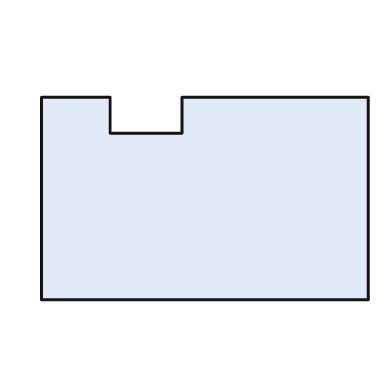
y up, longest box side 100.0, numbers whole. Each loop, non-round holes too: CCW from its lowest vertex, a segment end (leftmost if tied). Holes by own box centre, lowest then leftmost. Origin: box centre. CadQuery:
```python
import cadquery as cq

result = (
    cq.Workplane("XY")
    .moveTo(-50.0, -31.0)
    .lineTo(50.0, -31.0)
    .lineTo(50.0, 31.0)
    .lineTo(-7.0, 31.0)
    .lineTo(-7.0, 20.0)
    .lineTo(-29.0, 20.0)
    .lineTo(-29.0, 31.0)
    .lineTo(-50.0, 31.0)
    .close()
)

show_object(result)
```